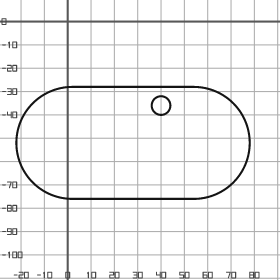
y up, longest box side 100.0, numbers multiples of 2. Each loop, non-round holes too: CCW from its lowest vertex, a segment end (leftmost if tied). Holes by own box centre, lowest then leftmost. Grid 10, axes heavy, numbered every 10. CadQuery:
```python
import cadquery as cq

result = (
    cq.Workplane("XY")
    .moveTo(2.0, -76.0)
    .lineTo(54.0, -76.0)
    .threePointArc((78.0, -52.0), (54.0, -28.0))
    .lineTo(2.0, -28.0)
    .threePointArc((-22.0, -52.0), (2.0, -76.0))
    .close()
    .moveTo(40.0, -36.0)
    .circle(4.0)
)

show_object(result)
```